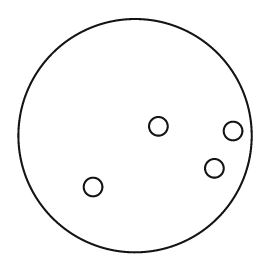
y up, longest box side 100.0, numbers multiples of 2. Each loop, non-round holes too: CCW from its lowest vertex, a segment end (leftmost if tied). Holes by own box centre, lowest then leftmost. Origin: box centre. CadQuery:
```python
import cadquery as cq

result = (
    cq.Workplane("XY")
    .moveTo(0.0, 0.0)
    .circle(50.0)
    .moveTo(-18.0, -22.0)
    .circle(4.0)
    .moveTo(34.0, -14.0)
    .circle(4.0)
    .moveTo(42.0, 2.0)
    .circle(4.0)
    .moveTo(10.0, 4.0)
    .circle(4.0)
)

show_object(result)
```